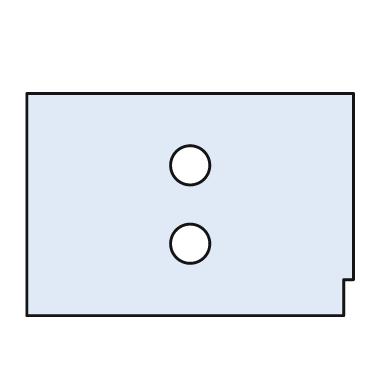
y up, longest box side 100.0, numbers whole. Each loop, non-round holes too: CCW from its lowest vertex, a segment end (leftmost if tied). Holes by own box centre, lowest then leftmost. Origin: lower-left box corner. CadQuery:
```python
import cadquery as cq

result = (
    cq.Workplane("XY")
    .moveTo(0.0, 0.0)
    .lineTo(97.0, 0.0)
    .lineTo(97.0, 11.0)
    .lineTo(100.0, 11.0)
    .lineTo(100.0, 68.0)
    .lineTo(0.0, 68.0)
    .close()
    .moveTo(50.0, 22.0)
    .circle(6.0)
    .moveTo(50.0, 46.0)
    .circle(6.0)
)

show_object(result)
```